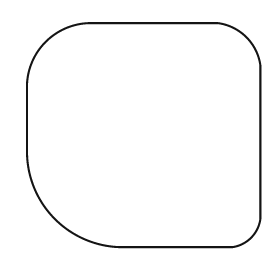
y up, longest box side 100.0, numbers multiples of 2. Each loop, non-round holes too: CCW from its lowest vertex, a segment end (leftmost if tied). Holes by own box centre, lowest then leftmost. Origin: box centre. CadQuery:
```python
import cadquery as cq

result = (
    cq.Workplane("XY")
    .moveTo(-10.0, -48.0)
    .lineTo(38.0, -48.0)
    .threePointArc((46.0, -44.0), (50.0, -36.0))
    .lineTo(50.0, 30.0)
    .threePointArc((44.0, 42.0), (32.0, 48.0))
    .lineTo(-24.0, 48.0)
    .threePointArc((-42.0, 40.0), (-50.0, 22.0))
    .lineTo(-50.0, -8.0)
    .threePointArc((-38.0, -36.0), (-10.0, -48.0))
    .close()
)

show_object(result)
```